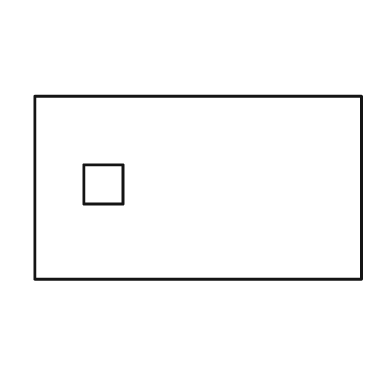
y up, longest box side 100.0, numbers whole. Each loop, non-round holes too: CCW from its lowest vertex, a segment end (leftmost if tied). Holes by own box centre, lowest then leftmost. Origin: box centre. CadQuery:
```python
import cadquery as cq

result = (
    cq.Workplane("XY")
    .moveTo(-50.0, -28.0)
    .lineTo(50.0, -28.0)
    .lineTo(50.0, 28.0)
    .lineTo(-50.0, 28.0)
    .close()
    .moveTo(-35.0, -5.0)
    .lineTo(-23.0, -5.0)
    .lineTo(-23.0, 7.0)
    .lineTo(-35.0, 7.0)
    .close()
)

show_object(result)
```